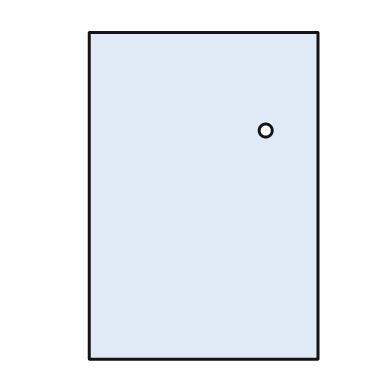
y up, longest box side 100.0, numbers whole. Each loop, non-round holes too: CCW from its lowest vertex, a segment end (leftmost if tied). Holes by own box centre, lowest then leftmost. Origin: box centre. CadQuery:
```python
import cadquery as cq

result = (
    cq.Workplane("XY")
    .moveTo(-35.0, -50.0)
    .lineTo(35.0, -50.0)
    .lineTo(35.0, 50.0)
    .lineTo(-35.0, 50.0)
    .close()
    .moveTo(19.0, 20.0)
    .circle(2.0)
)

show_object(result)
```